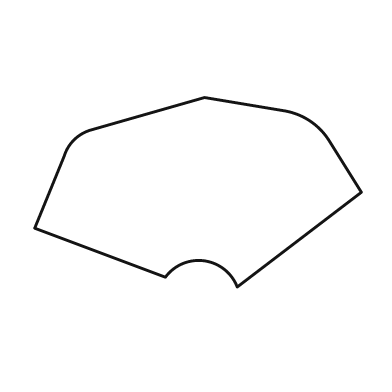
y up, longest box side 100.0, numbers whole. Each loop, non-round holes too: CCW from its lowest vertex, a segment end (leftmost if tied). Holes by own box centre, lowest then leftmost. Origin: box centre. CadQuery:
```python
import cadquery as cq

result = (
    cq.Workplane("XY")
    .moveTo(12.0, -29.0)
    .lineTo(50.0, 0.0)
    .lineTo(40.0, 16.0)
    .threePointArc((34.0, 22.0), (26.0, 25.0))
    .lineTo(2.0, 29.0)
    .lineTo(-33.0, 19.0)
    .threePointArc((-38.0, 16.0), (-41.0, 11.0))
    .lineTo(-50.0, -11.0)
    .lineTo(-10.0, -26.0)
    .threePointArc((2.0, -21.0), (12.0, -29.0))
    .close()
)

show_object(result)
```